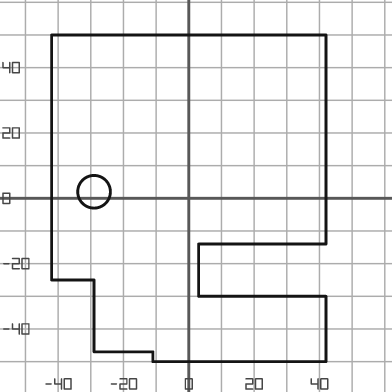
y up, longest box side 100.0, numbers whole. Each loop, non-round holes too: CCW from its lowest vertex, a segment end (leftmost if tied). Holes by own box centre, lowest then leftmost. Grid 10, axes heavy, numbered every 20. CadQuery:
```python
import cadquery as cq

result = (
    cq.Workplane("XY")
    .moveTo(-11.0, -50.0)
    .lineTo(42.0, -50.0)
    .lineTo(42.0, -30.0)
    .lineTo(3.0, -30.0)
    .lineTo(3.0, -14.0)
    .lineTo(42.0, -14.0)
    .lineTo(42.0, 50.0)
    .lineTo(-42.0, 50.0)
    .lineTo(-42.0, -25.0)
    .lineTo(-29.0, -25.0)
    .lineTo(-29.0, -47.0)
    .lineTo(-11.0, -47.0)
    .close()
    .moveTo(-29.0, 2.0)
    .circle(5.0)
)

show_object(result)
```